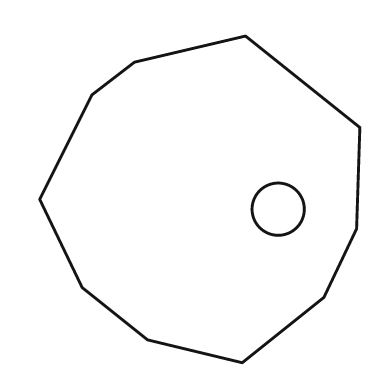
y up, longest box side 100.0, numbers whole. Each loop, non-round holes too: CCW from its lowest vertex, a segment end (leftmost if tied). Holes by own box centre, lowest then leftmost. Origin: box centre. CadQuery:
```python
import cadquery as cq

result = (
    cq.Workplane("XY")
    .moveTo(13.0, -50.0)
    .lineTo(38.0, -30.0)
    .lineTo(48.0, -9.0)
    .lineTo(49.0, 22.0)
    .lineTo(14.0, 50.0)
    .lineTo(-20.0, 42.0)
    .lineTo(-33.0, 32.0)
    .lineTo(-49.0, 0.0)
    .lineTo(-36.0, -27.0)
    .lineTo(-16.0, -43.0)
    .close()
    .moveTo(24.0, -3.0)
    .circle(8.0)
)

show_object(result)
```